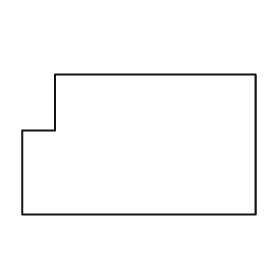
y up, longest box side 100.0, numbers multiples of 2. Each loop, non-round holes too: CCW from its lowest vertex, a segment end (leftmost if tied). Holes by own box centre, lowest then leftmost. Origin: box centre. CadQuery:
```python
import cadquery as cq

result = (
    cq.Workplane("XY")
    .moveTo(-50.0, -30.0)
    .lineTo(50.0, -30.0)
    .lineTo(50.0, 30.0)
    .lineTo(-36.0, 30.0)
    .lineTo(-36.0, 6.0)
    .lineTo(-50.0, 6.0)
    .close()
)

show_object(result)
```